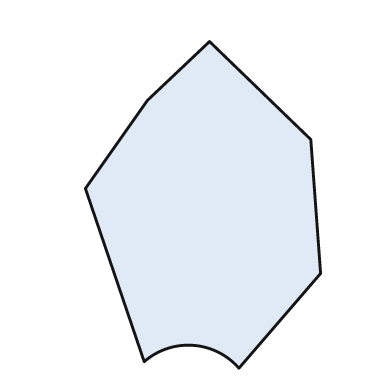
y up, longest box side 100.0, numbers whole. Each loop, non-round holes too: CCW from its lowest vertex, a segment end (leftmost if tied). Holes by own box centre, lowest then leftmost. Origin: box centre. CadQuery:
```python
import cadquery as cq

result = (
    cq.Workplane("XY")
    .moveTo(11.0, -50.0)
    .lineTo(36.0, -21.0)
    .lineTo(33.0, 20.0)
    .lineTo(2.0, 50.0)
    .lineTo(-17.0, 32.0)
    .lineTo(-36.0, 5.0)
    .lineTo(-18.0, -48.0)
    .threePointArc((-3.0, -43.0), (11.0, -50.0))
    .close()
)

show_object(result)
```